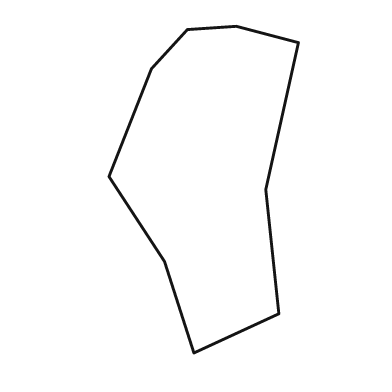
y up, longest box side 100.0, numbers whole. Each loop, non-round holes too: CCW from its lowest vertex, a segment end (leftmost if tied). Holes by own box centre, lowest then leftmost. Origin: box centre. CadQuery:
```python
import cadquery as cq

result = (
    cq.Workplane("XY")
    .moveTo(-3.0, -50.0)
    .lineTo(23.0, -38.0)
    .lineTo(19.0, 0.0)
    .lineTo(29.0, 45.0)
    .lineTo(10.0, 50.0)
    .lineTo(-5.0, 49.0)
    .lineTo(-16.0, 37.0)
    .lineTo(-29.0, 4.0)
    .lineTo(-12.0, -22.0)
    .close()
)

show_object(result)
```